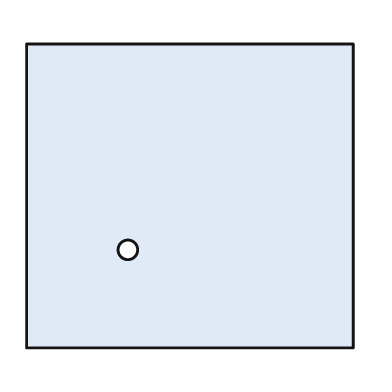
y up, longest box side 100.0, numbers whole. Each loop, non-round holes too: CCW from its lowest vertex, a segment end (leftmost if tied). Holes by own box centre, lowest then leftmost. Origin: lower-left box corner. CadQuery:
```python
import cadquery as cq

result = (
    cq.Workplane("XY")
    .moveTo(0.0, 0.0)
    .lineTo(100.0, 0.0)
    .lineTo(100.0, 93.0)
    .lineTo(0.0, 93.0)
    .close()
    .moveTo(31.0, 30.0)
    .circle(3.0)
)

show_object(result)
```